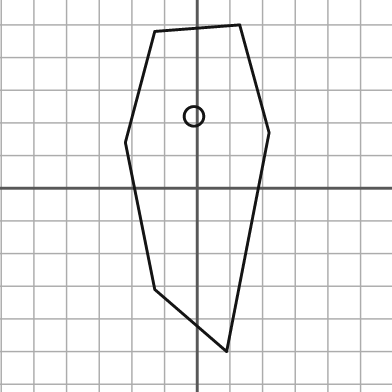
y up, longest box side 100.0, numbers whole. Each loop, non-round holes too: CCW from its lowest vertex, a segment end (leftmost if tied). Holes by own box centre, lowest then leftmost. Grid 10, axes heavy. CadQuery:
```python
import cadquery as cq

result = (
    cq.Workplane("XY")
    .moveTo(9.0, -50.0)
    .lineTo(22.0, 17.0)
    .lineTo(13.0, 50.0)
    .lineTo(-13.0, 48.0)
    .lineTo(-22.0, 14.0)
    .lineTo(-13.0, -31.0)
    .close()
    .moveTo(-1.0, 22.0)
    .circle(3.0)
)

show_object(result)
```